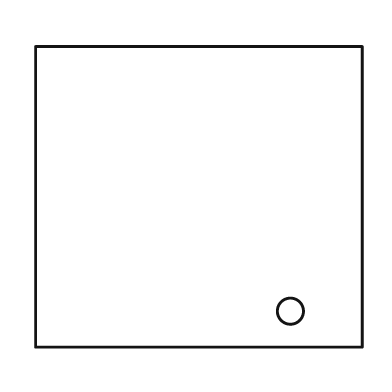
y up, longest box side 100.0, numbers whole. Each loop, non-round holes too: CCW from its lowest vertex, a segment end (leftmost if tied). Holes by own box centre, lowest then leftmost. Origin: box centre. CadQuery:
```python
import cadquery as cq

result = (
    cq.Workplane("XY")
    .moveTo(-50.0, -46.0)
    .lineTo(50.0, -46.0)
    .lineTo(50.0, 46.0)
    .lineTo(-50.0, 46.0)
    .close()
    .moveTo(28.0, -35.0)
    .circle(4.0)
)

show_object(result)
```